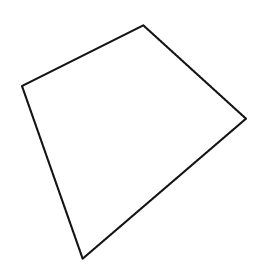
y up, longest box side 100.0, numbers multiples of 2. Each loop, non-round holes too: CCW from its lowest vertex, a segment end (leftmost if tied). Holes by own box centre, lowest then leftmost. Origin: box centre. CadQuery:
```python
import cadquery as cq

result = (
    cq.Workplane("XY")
    .moveTo(-22.0, -50.0)
    .lineTo(48.0, 10.0)
    .lineTo(4.0, 50.0)
    .lineTo(-48.0, 24.0)
    .close()
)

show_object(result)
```